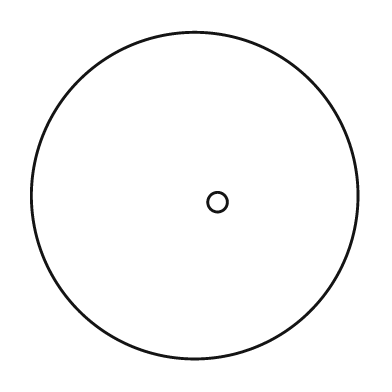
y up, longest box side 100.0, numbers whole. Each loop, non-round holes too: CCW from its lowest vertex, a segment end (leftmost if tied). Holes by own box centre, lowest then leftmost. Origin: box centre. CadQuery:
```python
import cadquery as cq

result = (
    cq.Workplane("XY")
    .moveTo(0.0, 0.0)
    .circle(50.0)
    .moveTo(7.0, -2.0)
    .circle(3.0)
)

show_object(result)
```